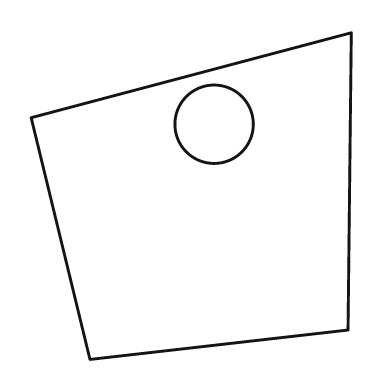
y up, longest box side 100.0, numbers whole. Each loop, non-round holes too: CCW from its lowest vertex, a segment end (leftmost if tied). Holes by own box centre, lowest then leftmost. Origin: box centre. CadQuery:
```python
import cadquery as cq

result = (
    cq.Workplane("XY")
    .moveTo(-31.0, -50.0)
    .lineTo(48.0, -41.0)
    .lineTo(49.0, 50.0)
    .lineTo(-49.0, 24.0)
    .close()
    .moveTo(7.0, 22.0)
    .circle(12.0)
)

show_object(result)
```